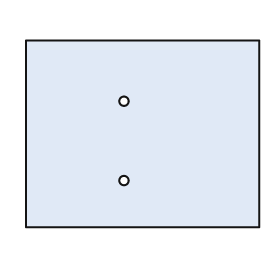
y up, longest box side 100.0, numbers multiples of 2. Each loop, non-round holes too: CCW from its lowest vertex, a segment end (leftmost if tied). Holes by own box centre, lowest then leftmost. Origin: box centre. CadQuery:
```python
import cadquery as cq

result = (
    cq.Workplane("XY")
    .moveTo(-50.0, -40.0)
    .lineTo(50.0, -40.0)
    .lineTo(50.0, 40.0)
    .lineTo(-50.0, 40.0)
    .close()
    .moveTo(-8.0, -20.0)
    .circle(2.0)
    .moveTo(-8.0, 14.0)
    .circle(2.0)
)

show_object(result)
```